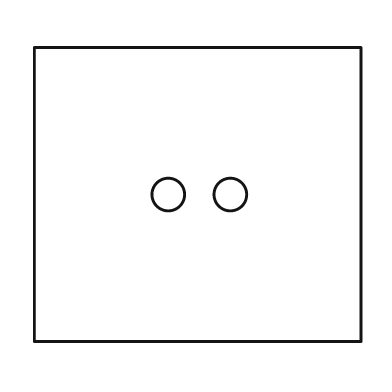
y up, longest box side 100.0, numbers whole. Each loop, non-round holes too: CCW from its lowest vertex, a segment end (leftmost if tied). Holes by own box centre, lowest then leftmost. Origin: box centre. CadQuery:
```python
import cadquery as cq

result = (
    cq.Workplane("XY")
    .moveTo(-50.0, -45.0)
    .lineTo(50.0, -45.0)
    .lineTo(50.0, 45.0)
    .lineTo(-50.0, 45.0)
    .close()
    .moveTo(-9.0, 0.0)
    .circle(5.0)
    .moveTo(10.0, 0.0)
    .circle(5.0)
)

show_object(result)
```